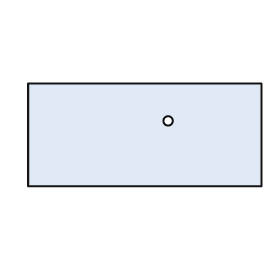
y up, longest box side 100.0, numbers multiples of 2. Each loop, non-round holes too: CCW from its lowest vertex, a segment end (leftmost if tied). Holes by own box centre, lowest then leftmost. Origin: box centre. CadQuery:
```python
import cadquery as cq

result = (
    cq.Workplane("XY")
    .moveTo(-50.0, -22.0)
    .lineTo(50.0, -22.0)
    .lineTo(50.0, 22.0)
    .lineTo(-50.0, 22.0)
    .close()
    .moveTo(10.0, 6.0)
    .circle(2.0)
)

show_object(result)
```